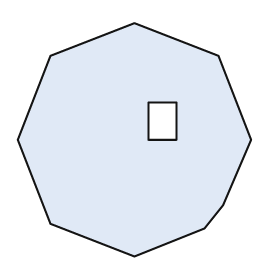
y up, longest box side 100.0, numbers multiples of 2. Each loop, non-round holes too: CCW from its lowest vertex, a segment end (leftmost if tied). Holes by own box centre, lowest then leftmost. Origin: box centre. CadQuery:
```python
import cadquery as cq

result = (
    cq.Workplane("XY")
    .moveTo(0.0, -50.0)
    .lineTo(30.0, -38.0)
    .lineTo(38.0, -28.0)
    .lineTo(50.0, 0.0)
    .lineTo(36.0, 36.0)
    .lineTo(0.0, 50.0)
    .lineTo(-36.0, 36.0)
    .lineTo(-50.0, 0.0)
    .lineTo(-36.0, -36.0)
    .close()
    .moveTo(6.0, 0.0)
    .lineTo(18.0, 0.0)
    .lineTo(18.0, 16.0)
    .lineTo(6.0, 16.0)
    .close()
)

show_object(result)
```